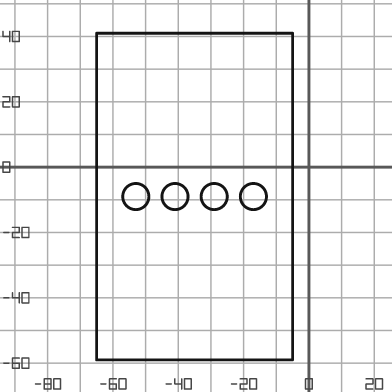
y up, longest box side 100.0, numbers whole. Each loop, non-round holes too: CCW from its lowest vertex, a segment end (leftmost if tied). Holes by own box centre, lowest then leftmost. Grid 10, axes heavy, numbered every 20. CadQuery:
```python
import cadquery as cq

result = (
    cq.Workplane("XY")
    .moveTo(-65.0, -59.0)
    .lineTo(-5.0, -59.0)
    .lineTo(-5.0, 41.0)
    .lineTo(-65.0, 41.0)
    .close()
    .moveTo(-53.0, -9.0)
    .circle(4.0)
    .moveTo(-41.0, -9.0)
    .circle(4.0)
    .moveTo(-29.0, -9.0)
    .circle(4.0)
    .moveTo(-17.0, -9.0)
    .circle(4.0)
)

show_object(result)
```